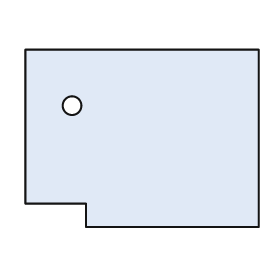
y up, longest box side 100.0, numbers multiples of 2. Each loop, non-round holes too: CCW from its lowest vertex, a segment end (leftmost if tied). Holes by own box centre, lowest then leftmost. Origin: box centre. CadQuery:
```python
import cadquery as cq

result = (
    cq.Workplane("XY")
    .moveTo(-24.0, -38.0)
    .lineTo(50.0, -38.0)
    .lineTo(50.0, 38.0)
    .lineTo(-50.0, 38.0)
    .lineTo(-50.0, -28.0)
    .lineTo(-24.0, -28.0)
    .close()
    .moveTo(-30.0, 14.0)
    .circle(4.0)
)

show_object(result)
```